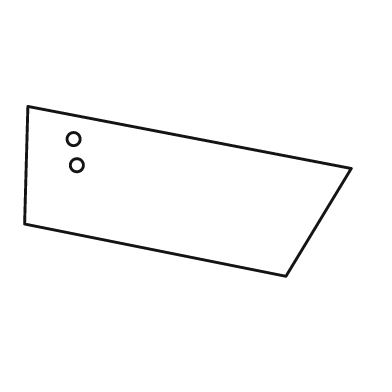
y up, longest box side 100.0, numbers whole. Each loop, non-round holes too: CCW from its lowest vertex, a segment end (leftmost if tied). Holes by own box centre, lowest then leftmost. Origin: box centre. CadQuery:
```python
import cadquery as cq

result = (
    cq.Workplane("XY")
    .moveTo(30.0, -26.0)
    .lineTo(50.0, 7.0)
    .lineTo(-49.0, 26.0)
    .lineTo(-50.0, -10.0)
    .close()
    .moveTo(-34.0, 8.0)
    .circle(2.0)
    .moveTo(-35.0, 16.0)
    .circle(2.0)
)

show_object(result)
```